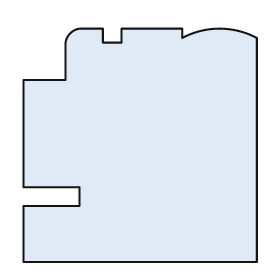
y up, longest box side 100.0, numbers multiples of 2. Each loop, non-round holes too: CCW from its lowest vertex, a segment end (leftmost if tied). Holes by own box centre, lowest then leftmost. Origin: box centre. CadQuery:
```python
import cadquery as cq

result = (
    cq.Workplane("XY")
    .moveTo(-50.0, -50.0)
    .lineTo(50.0, -50.0)
    .lineTo(50.0, 46.0)
    .threePointArc((34.0, 50.0), (18.0, 46.0))
    .lineTo(18.0, 50.0)
    .lineTo(-8.0, 50.0)
    .lineTo(-8.0, 44.0)
    .lineTo(-16.0, 44.0)
    .lineTo(-16.0, 50.0)
    .lineTo(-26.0, 50.0)
    .threePointArc((-30.0, 48.0), (-32.0, 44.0))
    .lineTo(-32.0, 28.0)
    .lineTo(-50.0, 28.0)
    .lineTo(-50.0, -18.0)
    .lineTo(-26.0, -18.0)
    .lineTo(-26.0, -26.0)
    .lineTo(-50.0, -26.0)
    .close()
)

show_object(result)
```